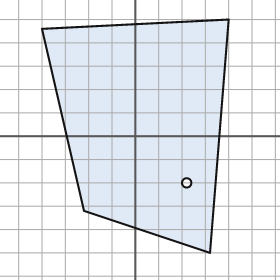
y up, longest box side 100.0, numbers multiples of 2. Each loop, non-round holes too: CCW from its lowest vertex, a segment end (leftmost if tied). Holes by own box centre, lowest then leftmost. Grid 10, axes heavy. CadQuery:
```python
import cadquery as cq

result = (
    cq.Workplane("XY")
    .moveTo(32.0, -50.0)
    .lineTo(40.0, 50.0)
    .lineTo(-40.0, 46.0)
    .lineTo(-22.0, -32.0)
    .close()
    .moveTo(22.0, -20.0)
    .circle(2.0)
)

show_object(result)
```